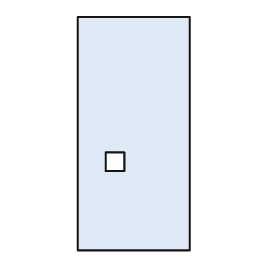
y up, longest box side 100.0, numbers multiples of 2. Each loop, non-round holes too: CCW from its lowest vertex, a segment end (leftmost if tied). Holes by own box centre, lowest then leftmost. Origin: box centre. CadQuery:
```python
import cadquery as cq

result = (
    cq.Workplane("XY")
    .moveTo(-24.0, -50.0)
    .lineTo(24.0, -50.0)
    .lineTo(24.0, 50.0)
    .lineTo(-24.0, 50.0)
    .close()
    .moveTo(-12.0, -16.0)
    .lineTo(-4.0, -16.0)
    .lineTo(-4.0, -8.0)
    .lineTo(-12.0, -8.0)
    .close()
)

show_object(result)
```